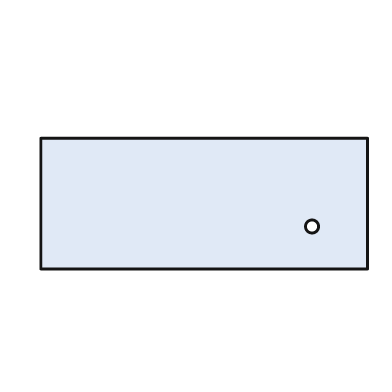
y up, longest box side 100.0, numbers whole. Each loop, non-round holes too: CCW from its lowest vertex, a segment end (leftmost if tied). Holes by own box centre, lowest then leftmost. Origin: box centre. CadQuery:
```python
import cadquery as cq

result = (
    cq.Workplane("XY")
    .moveTo(-50.0, -20.0)
    .lineTo(50.0, -20.0)
    .lineTo(50.0, 20.0)
    .lineTo(-50.0, 20.0)
    .close()
    .moveTo(33.0, -7.0)
    .circle(2.0)
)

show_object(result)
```